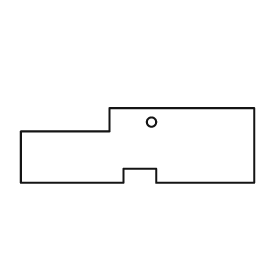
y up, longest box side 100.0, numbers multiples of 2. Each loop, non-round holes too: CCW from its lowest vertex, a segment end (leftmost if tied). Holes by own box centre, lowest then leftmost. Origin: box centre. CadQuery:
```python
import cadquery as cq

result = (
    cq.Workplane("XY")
    .moveTo(-50.0, -16.0)
    .lineTo(-6.0, -16.0)
    .lineTo(-6.0, -10.0)
    .lineTo(8.0, -10.0)
    .lineTo(8.0, -16.0)
    .lineTo(50.0, -16.0)
    .lineTo(50.0, 16.0)
    .lineTo(-12.0, 16.0)
    .lineTo(-12.0, 6.0)
    .lineTo(-50.0, 6.0)
    .close()
    .moveTo(6.0, 10.0)
    .circle(2.0)
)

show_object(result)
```